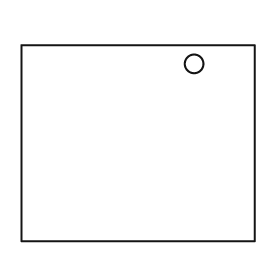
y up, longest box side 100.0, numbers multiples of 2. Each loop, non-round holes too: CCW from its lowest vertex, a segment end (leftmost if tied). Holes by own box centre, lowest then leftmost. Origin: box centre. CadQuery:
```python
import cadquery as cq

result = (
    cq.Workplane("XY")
    .moveTo(-50.0, -42.0)
    .lineTo(50.0, -42.0)
    .lineTo(50.0, 42.0)
    .lineTo(-50.0, 42.0)
    .close()
    .moveTo(24.0, 34.0)
    .circle(4.0)
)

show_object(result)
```